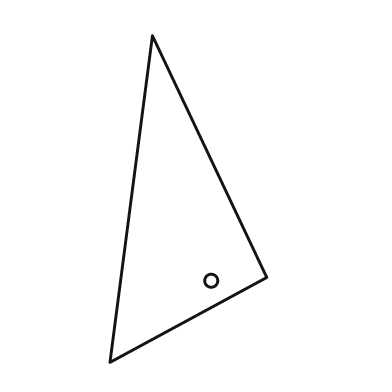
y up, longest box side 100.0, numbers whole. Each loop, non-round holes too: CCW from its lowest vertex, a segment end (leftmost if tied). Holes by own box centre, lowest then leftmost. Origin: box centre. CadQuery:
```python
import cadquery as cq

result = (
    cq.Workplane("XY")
    .moveTo(-24.0, -50.0)
    .lineTo(24.0, -24.0)
    .lineTo(-11.0, 50.0)
    .close()
    .moveTo(7.0, -25.0)
    .circle(2.0)
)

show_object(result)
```